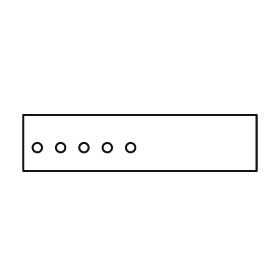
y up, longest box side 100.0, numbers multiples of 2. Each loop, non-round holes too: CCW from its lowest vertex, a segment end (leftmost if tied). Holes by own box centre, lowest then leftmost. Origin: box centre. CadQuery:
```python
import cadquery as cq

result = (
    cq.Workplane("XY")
    .moveTo(-50.0, -12.0)
    .lineTo(50.0, -12.0)
    .lineTo(50.0, 12.0)
    .lineTo(-50.0, 12.0)
    .close()
    .moveTo(-44.0, -2.0)
    .circle(2.0)
    .moveTo(-34.0, -2.0)
    .circle(2.0)
    .moveTo(-24.0, -2.0)
    .circle(2.0)
    .moveTo(-14.0, -2.0)
    .circle(2.0)
    .moveTo(-4.0, -2.0)
    .circle(2.0)
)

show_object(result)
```